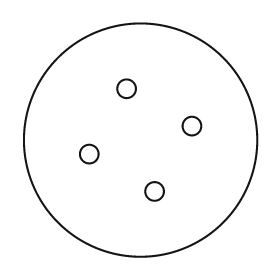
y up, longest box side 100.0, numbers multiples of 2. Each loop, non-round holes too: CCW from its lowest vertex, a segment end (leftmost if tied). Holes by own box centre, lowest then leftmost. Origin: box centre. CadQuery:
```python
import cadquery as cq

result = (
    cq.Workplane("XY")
    .moveTo(0.0, 0.0)
    .circle(50.0)
    .moveTo(6.0, -22.0)
    .circle(4.0)
    .moveTo(-22.0, -6.0)
    .circle(4.0)
    .moveTo(22.0, 6.0)
    .circle(4.0)
    .moveTo(-6.0, 22.0)
    .circle(4.0)
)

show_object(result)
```